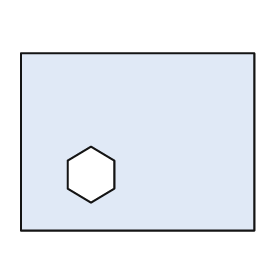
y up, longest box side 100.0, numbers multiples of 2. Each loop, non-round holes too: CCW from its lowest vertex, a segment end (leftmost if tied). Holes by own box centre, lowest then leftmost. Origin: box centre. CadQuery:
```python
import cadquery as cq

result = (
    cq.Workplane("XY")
    .moveTo(-50.0, -38.0)
    .lineTo(50.0, -38.0)
    .lineTo(50.0, 38.0)
    .lineTo(-50.0, 38.0)
    .close()
    .moveTo(-20.0, -26.0)
    .lineTo(-10.0, -20.0)
    .lineTo(-10.0, -8.0)
    .lineTo(-20.0, -2.0)
    .lineTo(-30.0, -8.0)
    .lineTo(-30.0, -20.0)
    .close()
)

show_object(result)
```